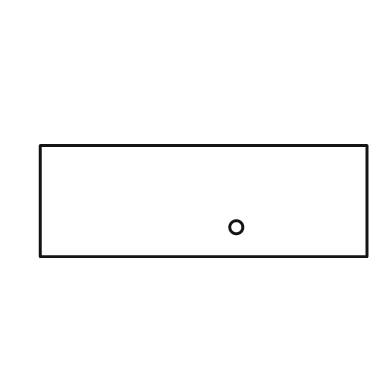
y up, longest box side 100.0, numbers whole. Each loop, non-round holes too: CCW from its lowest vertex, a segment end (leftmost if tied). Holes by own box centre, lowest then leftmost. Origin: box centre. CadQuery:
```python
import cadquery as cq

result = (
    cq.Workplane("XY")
    .moveTo(-50.0, -17.0)
    .lineTo(50.0, -17.0)
    .lineTo(50.0, 17.0)
    .lineTo(-50.0, 17.0)
    .close()
    .moveTo(10.0, -8.0)
    .circle(2.0)
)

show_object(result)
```